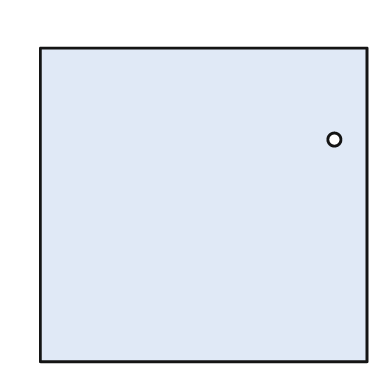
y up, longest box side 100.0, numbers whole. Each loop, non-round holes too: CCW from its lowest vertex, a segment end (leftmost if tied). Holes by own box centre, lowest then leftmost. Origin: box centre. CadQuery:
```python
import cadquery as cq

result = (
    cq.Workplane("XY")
    .moveTo(-50.0, -48.0)
    .lineTo(50.0, -48.0)
    .lineTo(50.0, 48.0)
    .lineTo(-50.0, 48.0)
    .close()
    .moveTo(40.0, 20.0)
    .circle(2.0)
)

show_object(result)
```